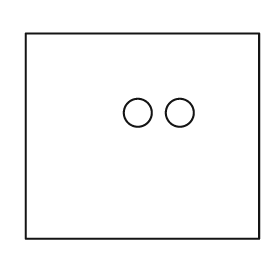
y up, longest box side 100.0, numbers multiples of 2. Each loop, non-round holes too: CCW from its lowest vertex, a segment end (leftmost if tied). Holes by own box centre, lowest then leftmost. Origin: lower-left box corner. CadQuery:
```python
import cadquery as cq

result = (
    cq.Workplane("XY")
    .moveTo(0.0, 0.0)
    .lineTo(100.0, 0.0)
    .lineTo(100.0, 88.0)
    .lineTo(0.0, 88.0)
    .close()
    .moveTo(48.0, 54.0)
    .circle(6.0)
    .moveTo(66.0, 54.0)
    .circle(6.0)
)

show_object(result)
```